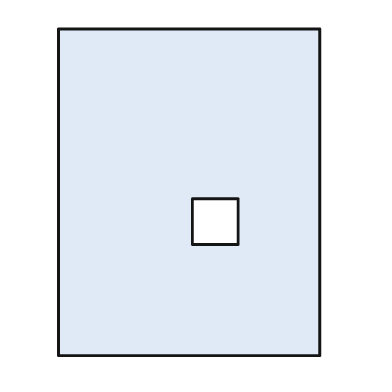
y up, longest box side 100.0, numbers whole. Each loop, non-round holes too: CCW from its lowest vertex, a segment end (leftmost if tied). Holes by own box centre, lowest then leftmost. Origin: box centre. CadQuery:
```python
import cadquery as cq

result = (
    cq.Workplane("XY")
    .moveTo(-40.0, -50.0)
    .lineTo(40.0, -50.0)
    .lineTo(40.0, 50.0)
    .lineTo(-40.0, 50.0)
    .close()
    .moveTo(1.0, -16.0)
    .lineTo(15.0, -16.0)
    .lineTo(15.0, -2.0)
    .lineTo(1.0, -2.0)
    .close()
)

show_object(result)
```